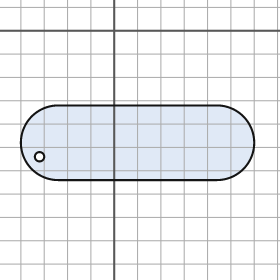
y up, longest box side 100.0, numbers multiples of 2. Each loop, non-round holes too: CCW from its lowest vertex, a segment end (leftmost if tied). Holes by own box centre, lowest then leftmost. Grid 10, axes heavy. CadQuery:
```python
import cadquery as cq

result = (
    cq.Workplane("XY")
    .moveTo(-24.0, -64.0)
    .lineTo(44.0, -64.0)
    .threePointArc((60.0, -48.0), (44.0, -32.0))
    .lineTo(-24.0, -32.0)
    .threePointArc((-40.0, -48.0), (-24.0, -64.0))
    .close()
    .moveTo(-32.0, -54.0)
    .circle(2.0)
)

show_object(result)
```